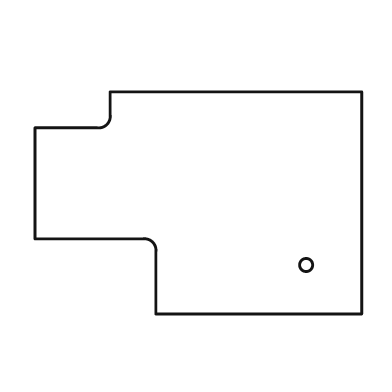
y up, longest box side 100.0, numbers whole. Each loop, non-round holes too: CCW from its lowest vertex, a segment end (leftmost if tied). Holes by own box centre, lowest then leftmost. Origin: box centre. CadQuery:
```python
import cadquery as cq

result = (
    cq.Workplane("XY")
    .moveTo(-13.0, -34.0)
    .lineTo(50.0, -34.0)
    .lineTo(50.0, 34.0)
    .lineTo(-27.0, 34.0)
    .lineTo(-27.0, 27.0)
    .threePointArc((-28.0, 24.0), (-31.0, 23.0))
    .lineTo(-50.0, 23.0)
    .lineTo(-50.0, -11.0)
    .lineTo(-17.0, -11.0)
    .threePointArc((-14.0, -12.0), (-13.0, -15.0))
    .close()
    .moveTo(33.0, -19.0)
    .circle(2.0)
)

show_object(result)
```